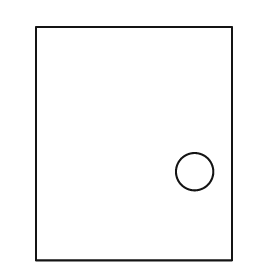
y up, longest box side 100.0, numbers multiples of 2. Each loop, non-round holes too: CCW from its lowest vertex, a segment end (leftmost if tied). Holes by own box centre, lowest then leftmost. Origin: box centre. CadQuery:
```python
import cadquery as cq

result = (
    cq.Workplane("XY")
    .moveTo(-42.0, -50.0)
    .lineTo(42.0, -50.0)
    .lineTo(42.0, 50.0)
    .lineTo(-42.0, 50.0)
    .close()
    .moveTo(26.0, -12.0)
    .circle(8.0)
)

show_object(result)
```